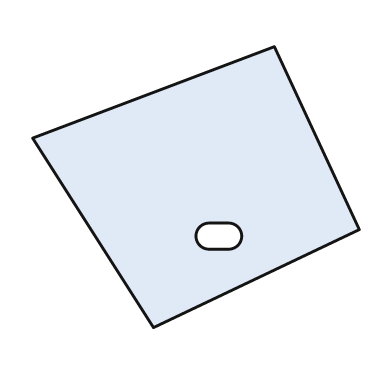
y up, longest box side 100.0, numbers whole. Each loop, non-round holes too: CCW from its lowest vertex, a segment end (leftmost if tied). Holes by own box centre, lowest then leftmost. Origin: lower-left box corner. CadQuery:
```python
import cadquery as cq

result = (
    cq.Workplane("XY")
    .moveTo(37.0, 0.0)
    .lineTo(100.0, 30.0)
    .lineTo(74.0, 86.0)
    .lineTo(0.0, 58.0)
    .close()
    .moveTo(54.0, 24.0)
    .lineTo(60.0, 24.0)
    .threePointArc((64.0, 28.0), (60.0, 32.0))
    .lineTo(54.0, 32.0)
    .threePointArc((50.0, 28.0), (54.0, 24.0))
    .close()
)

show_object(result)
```